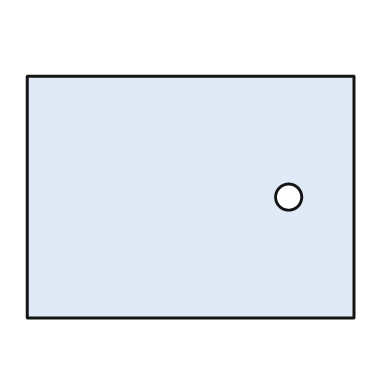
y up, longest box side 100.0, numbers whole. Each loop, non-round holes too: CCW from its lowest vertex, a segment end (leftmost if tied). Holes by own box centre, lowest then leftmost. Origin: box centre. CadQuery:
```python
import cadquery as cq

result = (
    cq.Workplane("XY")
    .moveTo(-50.0, -37.0)
    .lineTo(50.0, -37.0)
    .lineTo(50.0, 37.0)
    .lineTo(-50.0, 37.0)
    .close()
    .moveTo(30.0, 0.0)
    .circle(4.0)
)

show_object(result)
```